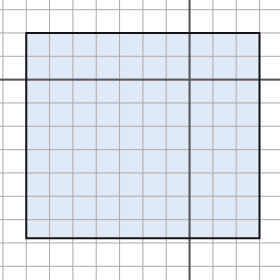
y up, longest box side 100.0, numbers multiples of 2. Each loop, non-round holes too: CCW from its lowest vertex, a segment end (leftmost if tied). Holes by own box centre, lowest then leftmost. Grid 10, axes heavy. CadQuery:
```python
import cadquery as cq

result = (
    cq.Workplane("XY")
    .moveTo(-70.0, -68.0)
    .lineTo(30.0, -68.0)
    .lineTo(30.0, 20.0)
    .lineTo(-70.0, 20.0)
    .close()
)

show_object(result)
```